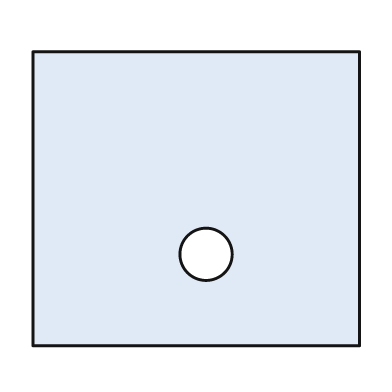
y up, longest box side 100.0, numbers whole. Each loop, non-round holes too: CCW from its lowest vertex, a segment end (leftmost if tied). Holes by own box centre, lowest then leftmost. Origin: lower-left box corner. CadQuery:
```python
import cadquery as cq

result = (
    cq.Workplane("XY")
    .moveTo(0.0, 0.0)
    .lineTo(100.0, 0.0)
    .lineTo(100.0, 90.0)
    .lineTo(0.0, 90.0)
    .close()
    .moveTo(53.0, 28.0)
    .circle(8.0)
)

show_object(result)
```